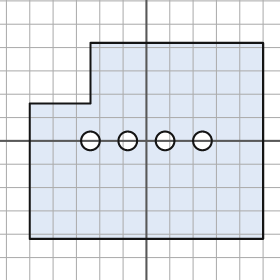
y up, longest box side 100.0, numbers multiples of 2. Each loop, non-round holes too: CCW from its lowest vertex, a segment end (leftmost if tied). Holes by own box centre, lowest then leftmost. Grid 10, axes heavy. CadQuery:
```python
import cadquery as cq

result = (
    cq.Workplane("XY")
    .moveTo(-50.0, -42.0)
    .lineTo(50.0, -42.0)
    .lineTo(50.0, 42.0)
    .lineTo(-24.0, 42.0)
    .lineTo(-24.0, 16.0)
    .lineTo(-50.0, 16.0)
    .close()
    .moveTo(-24.0, 0.0)
    .circle(4.0)
    .moveTo(-8.0, 0.0)
    .circle(4.0)
    .moveTo(8.0, 0.0)
    .circle(4.0)
    .moveTo(24.0, 0.0)
    .circle(4.0)
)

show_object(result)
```